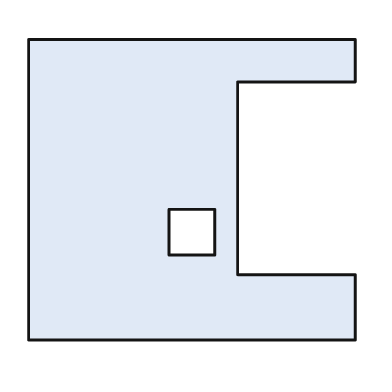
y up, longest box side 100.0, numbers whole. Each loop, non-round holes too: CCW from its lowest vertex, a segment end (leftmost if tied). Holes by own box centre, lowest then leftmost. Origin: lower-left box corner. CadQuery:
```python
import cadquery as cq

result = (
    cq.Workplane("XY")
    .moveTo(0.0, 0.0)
    .lineTo(100.0, 0.0)
    .lineTo(100.0, 20.0)
    .lineTo(64.0, 20.0)
    .lineTo(64.0, 79.0)
    .lineTo(100.0, 79.0)
    .lineTo(100.0, 92.0)
    .lineTo(0.0, 92.0)
    .close()
    .moveTo(43.0, 26.0)
    .lineTo(57.0, 26.0)
    .lineTo(57.0, 40.0)
    .lineTo(43.0, 40.0)
    .close()
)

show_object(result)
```